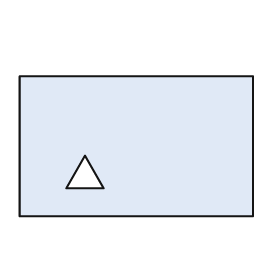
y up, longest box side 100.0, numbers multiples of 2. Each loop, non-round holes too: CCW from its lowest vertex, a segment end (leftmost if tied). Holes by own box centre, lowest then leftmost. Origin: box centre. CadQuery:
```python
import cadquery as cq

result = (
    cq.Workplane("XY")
    .moveTo(-50.0, -30.0)
    .lineTo(50.0, -30.0)
    .lineTo(50.0, 30.0)
    .lineTo(-50.0, 30.0)
    .close()
    .moveTo(-30.0, -18.0)
    .lineTo(-14.0, -18.0)
    .lineTo(-22.0, -4.0)
    .close()
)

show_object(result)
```